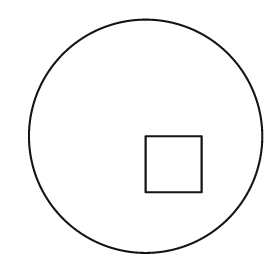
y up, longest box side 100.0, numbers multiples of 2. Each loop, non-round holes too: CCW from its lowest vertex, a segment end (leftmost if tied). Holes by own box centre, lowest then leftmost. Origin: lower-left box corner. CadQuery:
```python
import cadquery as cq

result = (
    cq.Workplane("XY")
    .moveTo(50.0, 50.0)
    .circle(50.0)
    .moveTo(50.0, 26.0)
    .lineTo(74.0, 26.0)
    .lineTo(74.0, 50.0)
    .lineTo(50.0, 50.0)
    .close()
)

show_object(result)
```